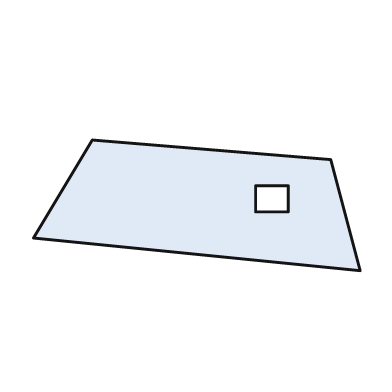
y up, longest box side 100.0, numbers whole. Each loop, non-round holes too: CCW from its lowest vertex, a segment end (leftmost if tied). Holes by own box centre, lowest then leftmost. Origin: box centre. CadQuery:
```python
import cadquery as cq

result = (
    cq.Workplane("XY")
    .moveTo(50.0, -20.0)
    .lineTo(41.0, 14.0)
    .lineTo(-32.0, 20.0)
    .lineTo(-50.0, -10.0)
    .close()
    .moveTo(18.0, -2.0)
    .lineTo(28.0, -2.0)
    .lineTo(28.0, 6.0)
    .lineTo(18.0, 6.0)
    .close()
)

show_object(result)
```